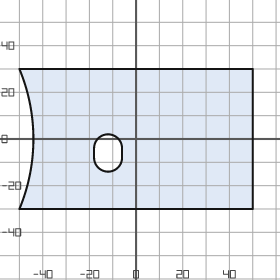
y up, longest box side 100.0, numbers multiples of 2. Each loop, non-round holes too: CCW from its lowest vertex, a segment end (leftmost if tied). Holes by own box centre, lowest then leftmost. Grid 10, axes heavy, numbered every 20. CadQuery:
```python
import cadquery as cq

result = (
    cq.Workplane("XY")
    .moveTo(-50.0, -30.0)
    .lineTo(50.0, -30.0)
    .lineTo(50.0, 30.0)
    .lineTo(-50.0, 30.0)
    .threePointArc((-44.0, 0.0), (-50.0, -30.0))
    .close()
    .moveTo(-18.0, -8.0)
    .threePointArc((-12.0, -14.0), (-6.0, -8.0))
    .lineTo(-6.0, -4.0)
    .threePointArc((-12.0, 2.0), (-18.0, -4.0))
    .close()
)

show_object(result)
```